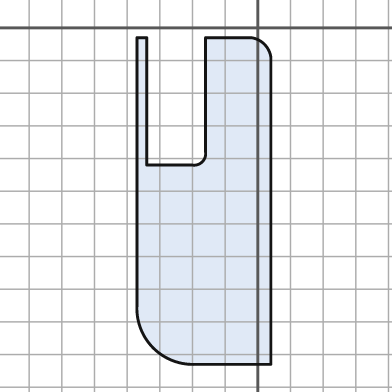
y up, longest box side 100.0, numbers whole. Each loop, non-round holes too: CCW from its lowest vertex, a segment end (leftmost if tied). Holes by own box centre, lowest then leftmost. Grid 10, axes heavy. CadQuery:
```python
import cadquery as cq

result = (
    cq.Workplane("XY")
    .moveTo(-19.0, -103.0)
    .lineTo(4.0, -103.0)
    .lineTo(4.0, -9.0)
    .threePointArc((2.0, -5.0), (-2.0, -3.0))
    .lineTo(-16.0, -3.0)
    .lineTo(-16.0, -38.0)
    .threePointArc((-17.0, -41.0), (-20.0, -42.0))
    .lineTo(-34.0, -42.0)
    .lineTo(-34.0, -3.0)
    .lineTo(-37.0, -3.0)
    .lineTo(-37.0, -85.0)
    .threePointArc((-32.0, -98.0), (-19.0, -103.0))
    .close()
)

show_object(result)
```